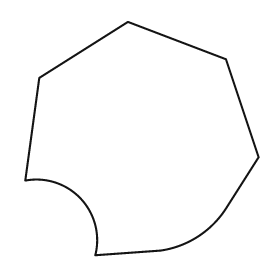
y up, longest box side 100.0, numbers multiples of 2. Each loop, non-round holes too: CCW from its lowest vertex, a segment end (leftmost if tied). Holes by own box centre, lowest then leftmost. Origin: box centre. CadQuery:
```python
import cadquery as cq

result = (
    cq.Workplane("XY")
    .moveTo(-20.0, -50.0)
    .lineTo(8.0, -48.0)
    .threePointArc((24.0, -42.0), (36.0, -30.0))
    .lineTo(50.0, -8.0)
    .lineTo(36.0, 34.0)
    .lineTo(-6.0, 50.0)
    .lineTo(-44.0, 26.0)
    .lineTo(-50.0, -18.0)
    .threePointArc((-26.0, -26.0), (-20.0, -50.0))
    .close()
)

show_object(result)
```